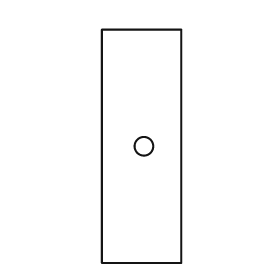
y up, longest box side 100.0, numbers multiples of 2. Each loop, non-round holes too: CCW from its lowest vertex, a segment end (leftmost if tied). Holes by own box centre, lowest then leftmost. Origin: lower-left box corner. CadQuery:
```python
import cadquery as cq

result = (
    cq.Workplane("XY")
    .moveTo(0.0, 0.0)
    .lineTo(34.0, 0.0)
    .lineTo(34.0, 100.0)
    .lineTo(0.0, 100.0)
    .close()
    .moveTo(18.0, 50.0)
    .circle(4.0)
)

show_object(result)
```